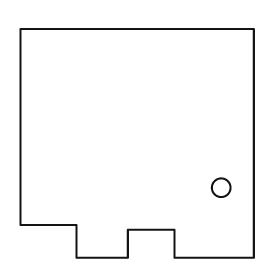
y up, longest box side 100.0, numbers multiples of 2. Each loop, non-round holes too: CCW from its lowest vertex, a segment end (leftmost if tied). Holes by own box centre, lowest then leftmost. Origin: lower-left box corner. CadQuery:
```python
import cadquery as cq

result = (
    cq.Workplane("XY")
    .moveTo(24.0, 0.0)
    .lineTo(46.0, 0.0)
    .lineTo(46.0, 12.0)
    .lineTo(66.0, 12.0)
    .lineTo(66.0, 0.0)
    .lineTo(100.0, 0.0)
    .lineTo(100.0, 98.0)
    .lineTo(0.0, 98.0)
    .lineTo(0.0, 14.0)
    .lineTo(24.0, 14.0)
    .close()
    .moveTo(86.0, 30.0)
    .circle(4.0)
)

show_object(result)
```